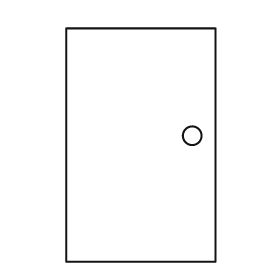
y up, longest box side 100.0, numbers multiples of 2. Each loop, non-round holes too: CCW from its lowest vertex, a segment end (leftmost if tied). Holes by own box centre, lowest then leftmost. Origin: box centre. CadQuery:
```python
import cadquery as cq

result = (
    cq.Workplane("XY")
    .moveTo(-32.0, -50.0)
    .lineTo(32.0, -50.0)
    .lineTo(32.0, 50.0)
    .lineTo(-32.0, 50.0)
    .close()
    .moveTo(22.0, 4.0)
    .circle(4.0)
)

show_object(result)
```